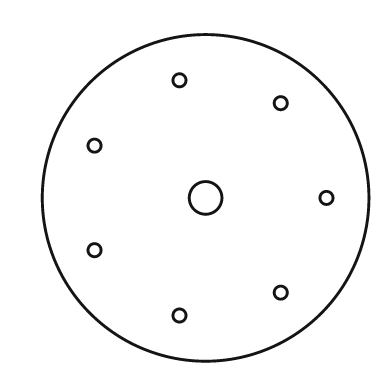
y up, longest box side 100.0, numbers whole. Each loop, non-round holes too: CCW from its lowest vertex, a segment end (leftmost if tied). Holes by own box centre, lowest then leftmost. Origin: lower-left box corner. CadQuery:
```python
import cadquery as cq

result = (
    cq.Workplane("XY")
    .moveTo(50.0, 50.0)
    .circle(50.0)
    .moveTo(42.0, 14.0)
    .circle(2.0)
    .moveTo(73.0, 21.0)
    .circle(2.0)
    .moveTo(16.0, 34.0)
    .circle(2.0)
    .moveTo(50.0, 50.0)
    .circle(5.0)
    .moveTo(87.0, 50.0)
    .circle(2.0)
    .moveTo(16.0, 66.0)
    .circle(2.0)
    .moveTo(73.0, 79.0)
    .circle(2.0)
    .moveTo(42.0, 86.0)
    .circle(2.0)
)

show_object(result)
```